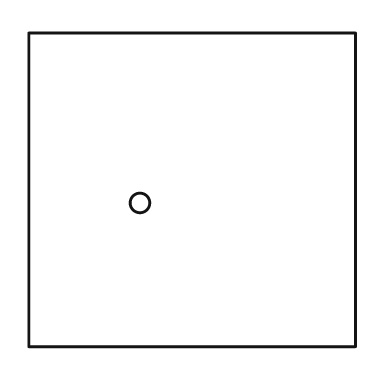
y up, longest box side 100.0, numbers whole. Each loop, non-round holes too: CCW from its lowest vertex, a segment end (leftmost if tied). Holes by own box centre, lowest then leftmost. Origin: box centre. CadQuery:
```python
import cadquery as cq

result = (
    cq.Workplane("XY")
    .moveTo(-50.0, -48.0)
    .lineTo(50.0, -48.0)
    .lineTo(50.0, 48.0)
    .lineTo(-50.0, 48.0)
    .close()
    .moveTo(-16.0, -4.0)
    .circle(3.0)
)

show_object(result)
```